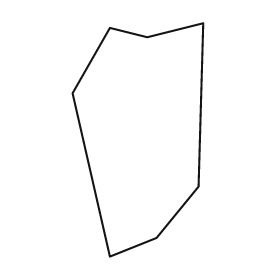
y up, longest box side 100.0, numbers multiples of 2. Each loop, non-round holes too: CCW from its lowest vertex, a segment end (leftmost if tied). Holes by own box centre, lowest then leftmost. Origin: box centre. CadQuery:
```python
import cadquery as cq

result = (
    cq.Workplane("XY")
    .moveTo(-12.0, -50.0)
    .lineTo(8.0, -42.0)
    .lineTo(26.0, -20.0)
    .lineTo(28.0, 50.0)
    .lineTo(4.0, 44.0)
    .lineTo(-12.0, 48.0)
    .lineTo(-28.0, 20.0)
    .close()
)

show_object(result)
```